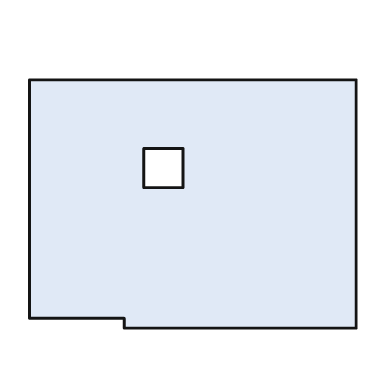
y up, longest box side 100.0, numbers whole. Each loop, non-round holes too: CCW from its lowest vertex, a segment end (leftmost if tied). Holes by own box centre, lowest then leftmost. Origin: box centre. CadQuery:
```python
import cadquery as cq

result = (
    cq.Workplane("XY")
    .moveTo(-21.0, -38.0)
    .lineTo(50.0, -38.0)
    .lineTo(50.0, 38.0)
    .lineTo(-50.0, 38.0)
    .lineTo(-50.0, -35.0)
    .lineTo(-21.0, -35.0)
    .close()
    .moveTo(-15.0, 5.0)
    .lineTo(-3.0, 5.0)
    .lineTo(-3.0, 17.0)
    .lineTo(-15.0, 17.0)
    .close()
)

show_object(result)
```